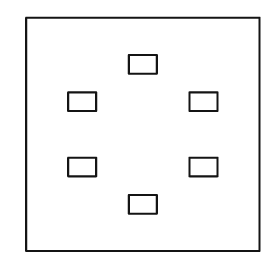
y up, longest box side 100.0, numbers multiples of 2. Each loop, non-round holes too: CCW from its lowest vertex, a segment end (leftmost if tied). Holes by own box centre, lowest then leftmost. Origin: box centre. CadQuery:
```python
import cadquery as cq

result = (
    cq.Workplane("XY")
    .moveTo(-50.0, -50.0)
    .lineTo(50.0, -50.0)
    .lineTo(50.0, 50.0)
    .lineTo(-50.0, 50.0)
    .close()
    .moveTo(-6.0, -34.0)
    .lineTo(6.0, -34.0)
    .lineTo(6.0, -26.0)
    .lineTo(-6.0, -26.0)
    .close()
    .moveTo(-32.0, -18.0)
    .lineTo(-20.0, -18.0)
    .lineTo(-20.0, -10.0)
    .lineTo(-32.0, -10.0)
    .close()
    .moveTo(20.0, -18.0)
    .lineTo(32.0, -18.0)
    .lineTo(32.0, -10.0)
    .lineTo(20.0, -10.0)
    .close()
    .moveTo(-32.0, 10.0)
    .lineTo(-20.0, 10.0)
    .lineTo(-20.0, 18.0)
    .lineTo(-32.0, 18.0)
    .close()
    .moveTo(20.0, 10.0)
    .lineTo(32.0, 10.0)
    .lineTo(32.0, 18.0)
    .lineTo(20.0, 18.0)
    .close()
    .moveTo(-6.0, 26.0)
    .lineTo(6.0, 26.0)
    .lineTo(6.0, 34.0)
    .lineTo(-6.0, 34.0)
    .close()
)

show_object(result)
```